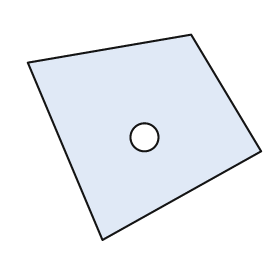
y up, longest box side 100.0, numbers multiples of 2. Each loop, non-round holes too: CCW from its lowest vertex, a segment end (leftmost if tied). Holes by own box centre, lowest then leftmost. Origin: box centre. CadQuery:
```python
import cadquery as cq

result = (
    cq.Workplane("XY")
    .moveTo(-18.0, -44.0)
    .lineTo(50.0, -6.0)
    .lineTo(20.0, 44.0)
    .lineTo(-50.0, 32.0)
    .close()
    .moveTo(0.0, 0.0)
    .circle(6.0)
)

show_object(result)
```